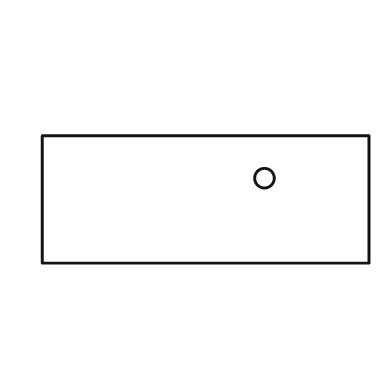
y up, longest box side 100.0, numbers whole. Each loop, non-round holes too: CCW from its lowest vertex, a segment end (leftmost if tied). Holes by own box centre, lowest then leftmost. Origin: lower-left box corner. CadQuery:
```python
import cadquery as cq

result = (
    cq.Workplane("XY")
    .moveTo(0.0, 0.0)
    .lineTo(100.0, 0.0)
    .lineTo(100.0, 39.0)
    .lineTo(0.0, 39.0)
    .close()
    .moveTo(68.0, 26.0)
    .circle(3.0)
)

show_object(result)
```